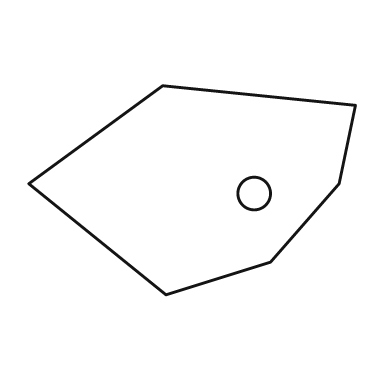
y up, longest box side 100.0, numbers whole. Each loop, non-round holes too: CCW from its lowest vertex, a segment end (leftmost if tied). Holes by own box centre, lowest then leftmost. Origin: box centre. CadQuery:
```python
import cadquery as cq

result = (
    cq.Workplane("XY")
    .moveTo(-8.0, -32.0)
    .lineTo(24.0, -22.0)
    .lineTo(45.0, 2.0)
    .lineTo(50.0, 26.0)
    .lineTo(-9.0, 32.0)
    .lineTo(-50.0, 2.0)
    .close()
    .moveTo(19.0, -1.0)
    .circle(5.0)
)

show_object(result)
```